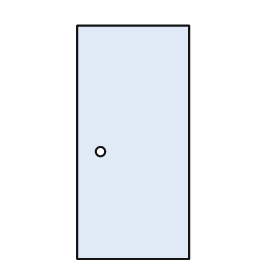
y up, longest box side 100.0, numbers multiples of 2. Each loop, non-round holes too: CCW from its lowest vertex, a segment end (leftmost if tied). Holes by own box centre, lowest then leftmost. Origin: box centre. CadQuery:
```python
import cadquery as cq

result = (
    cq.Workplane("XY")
    .moveTo(-24.0, -50.0)
    .lineTo(24.0, -50.0)
    .lineTo(24.0, 50.0)
    .lineTo(-24.0, 50.0)
    .close()
    .moveTo(-14.0, -4.0)
    .circle(2.0)
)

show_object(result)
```